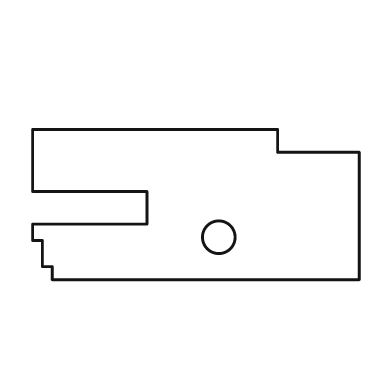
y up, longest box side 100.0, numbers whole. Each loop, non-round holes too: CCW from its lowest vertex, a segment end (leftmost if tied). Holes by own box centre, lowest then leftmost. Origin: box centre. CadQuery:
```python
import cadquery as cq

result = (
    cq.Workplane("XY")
    .moveTo(-44.0, -23.0)
    .lineTo(50.0, -23.0)
    .lineTo(50.0, 16.0)
    .lineTo(25.0, 16.0)
    .lineTo(25.0, 23.0)
    .lineTo(-50.0, 23.0)
    .lineTo(-50.0, 4.0)
    .lineTo(-15.0, 4.0)
    .lineTo(-15.0, -6.0)
    .lineTo(-50.0, -6.0)
    .lineTo(-50.0, -11.0)
    .lineTo(-47.0, -11.0)
    .lineTo(-47.0, -19.0)
    .lineTo(-44.0, -19.0)
    .close()
    .moveTo(7.0, -10.0)
    .circle(5.0)
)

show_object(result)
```